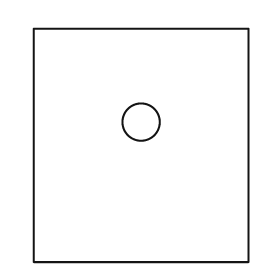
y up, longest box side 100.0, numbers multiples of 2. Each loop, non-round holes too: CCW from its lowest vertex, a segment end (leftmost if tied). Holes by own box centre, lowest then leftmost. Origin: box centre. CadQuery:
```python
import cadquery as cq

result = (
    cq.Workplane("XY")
    .moveTo(-46.0, -50.0)
    .lineTo(46.0, -50.0)
    .lineTo(46.0, 50.0)
    .lineTo(-46.0, 50.0)
    .close()
    .moveTo(0.0, 10.0)
    .circle(8.0)
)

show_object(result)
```